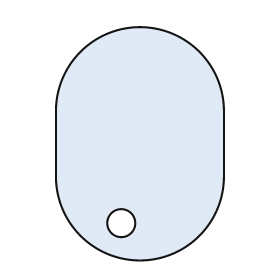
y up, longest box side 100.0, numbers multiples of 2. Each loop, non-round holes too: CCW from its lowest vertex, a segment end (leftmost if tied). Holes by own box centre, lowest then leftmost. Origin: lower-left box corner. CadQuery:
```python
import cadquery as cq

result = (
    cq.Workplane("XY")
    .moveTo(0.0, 36.0)
    .threePointArc((36.0, 0.0), (72.0, 36.0))
    .lineTo(72.0, 64.0)
    .threePointArc((36.0, 100.0), (0.0, 64.0))
    .close()
    .moveTo(28.0, 16.0)
    .circle(6.0)
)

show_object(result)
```